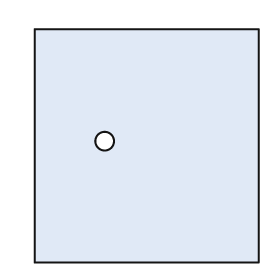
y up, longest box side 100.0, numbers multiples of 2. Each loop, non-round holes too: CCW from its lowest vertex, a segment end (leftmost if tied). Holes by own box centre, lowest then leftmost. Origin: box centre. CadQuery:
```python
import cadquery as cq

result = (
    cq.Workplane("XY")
    .moveTo(-48.0, -50.0)
    .lineTo(48.0, -50.0)
    .lineTo(48.0, 50.0)
    .lineTo(-48.0, 50.0)
    .close()
    .moveTo(-18.0, 2.0)
    .circle(4.0)
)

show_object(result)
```